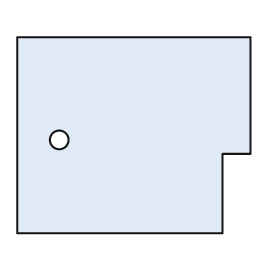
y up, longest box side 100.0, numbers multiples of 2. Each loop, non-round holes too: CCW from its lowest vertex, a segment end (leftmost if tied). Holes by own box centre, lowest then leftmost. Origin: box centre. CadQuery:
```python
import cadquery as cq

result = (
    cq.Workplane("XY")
    .moveTo(-50.0, -42.0)
    .lineTo(38.0, -42.0)
    .lineTo(38.0, -8.0)
    .lineTo(50.0, -8.0)
    .lineTo(50.0, 42.0)
    .lineTo(-50.0, 42.0)
    .close()
    .moveTo(-32.0, -2.0)
    .circle(4.0)
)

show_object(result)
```